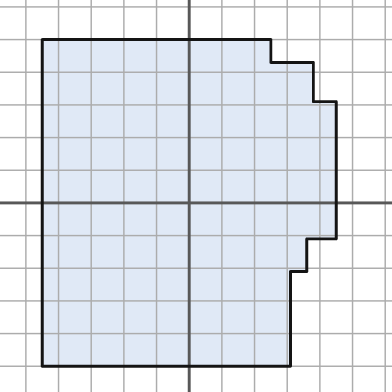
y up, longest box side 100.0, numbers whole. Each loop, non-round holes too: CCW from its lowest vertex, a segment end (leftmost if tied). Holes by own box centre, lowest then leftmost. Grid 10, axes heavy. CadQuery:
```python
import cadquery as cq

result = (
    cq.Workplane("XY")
    .moveTo(-45.0, -50.0)
    .lineTo(31.0, -50.0)
    .lineTo(31.0, -21.0)
    .lineTo(36.0, -21.0)
    .lineTo(36.0, -11.0)
    .lineTo(45.0, -11.0)
    .lineTo(45.0, 31.0)
    .lineTo(38.0, 31.0)
    .lineTo(38.0, 43.0)
    .lineTo(25.0, 43.0)
    .lineTo(25.0, 50.0)
    .lineTo(-45.0, 50.0)
    .close()
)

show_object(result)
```